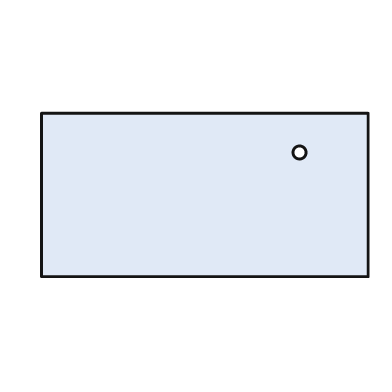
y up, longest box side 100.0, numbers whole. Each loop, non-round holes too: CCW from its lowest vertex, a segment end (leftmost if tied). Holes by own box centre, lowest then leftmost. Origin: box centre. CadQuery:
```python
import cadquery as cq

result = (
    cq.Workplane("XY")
    .moveTo(-50.0, -25.0)
    .lineTo(50.0, -25.0)
    .lineTo(50.0, 25.0)
    .lineTo(-50.0, 25.0)
    .close()
    .moveTo(29.0, 13.0)
    .circle(2.0)
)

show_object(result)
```